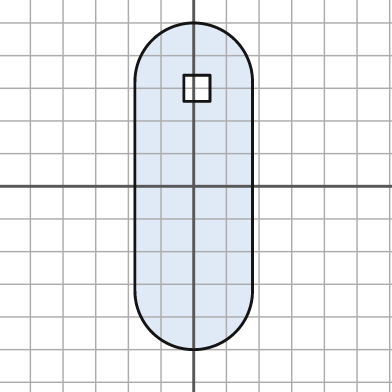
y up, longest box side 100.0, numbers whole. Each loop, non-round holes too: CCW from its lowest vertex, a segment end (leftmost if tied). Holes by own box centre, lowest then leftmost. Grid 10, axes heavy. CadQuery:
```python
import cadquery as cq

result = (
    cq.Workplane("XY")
    .moveTo(-18.0, -32.0)
    .threePointArc((0.0, -50.0), (18.0, -32.0))
    .lineTo(18.0, 32.0)
    .threePointArc((0.0, 50.0), (-18.0, 32.0))
    .close()
    .moveTo(-3.0, 26.0)
    .lineTo(5.0, 26.0)
    .lineTo(5.0, 34.0)
    .lineTo(-3.0, 34.0)
    .close()
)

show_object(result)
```